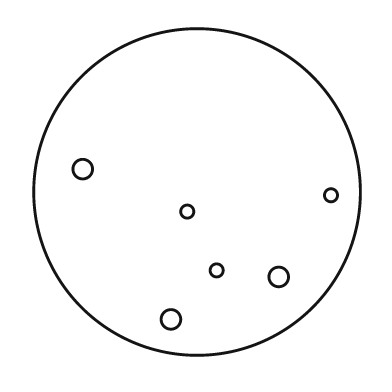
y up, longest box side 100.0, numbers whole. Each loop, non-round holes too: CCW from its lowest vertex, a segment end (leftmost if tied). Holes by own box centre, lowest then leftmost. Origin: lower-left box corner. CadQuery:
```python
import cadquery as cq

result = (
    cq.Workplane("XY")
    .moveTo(50.0, 50.0)
    .circle(50.0)
    .moveTo(42.0, 11.0)
    .circle(3.0)
    .moveTo(75.0, 24.0)
    .circle(3.0)
    .moveTo(56.0, 26.0)
    .circle(2.0)
    .moveTo(47.0, 44.0)
    .circle(2.0)
    .moveTo(91.0, 49.0)
    .circle(2.0)
    .moveTo(15.0, 57.0)
    .circle(3.0)
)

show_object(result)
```